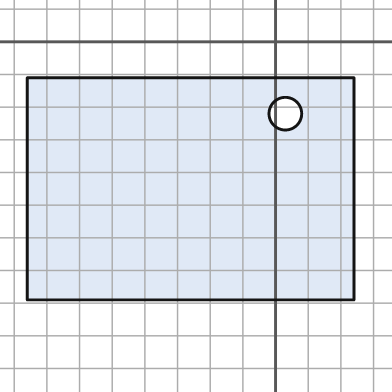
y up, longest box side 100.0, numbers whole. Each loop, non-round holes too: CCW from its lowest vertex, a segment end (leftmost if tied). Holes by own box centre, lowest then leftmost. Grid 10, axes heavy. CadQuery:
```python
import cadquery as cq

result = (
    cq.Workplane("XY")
    .moveTo(-76.0, -79.0)
    .lineTo(24.0, -79.0)
    .lineTo(24.0, -11.0)
    .lineTo(-76.0, -11.0)
    .close()
    .moveTo(3.0, -22.0)
    .circle(5.0)
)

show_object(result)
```